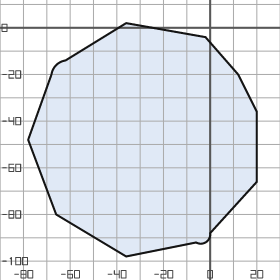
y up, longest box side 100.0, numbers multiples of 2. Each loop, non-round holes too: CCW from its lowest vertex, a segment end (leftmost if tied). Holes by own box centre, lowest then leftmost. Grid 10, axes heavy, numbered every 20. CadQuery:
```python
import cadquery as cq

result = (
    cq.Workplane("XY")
    .moveTo(-36.0, -98.0)
    .lineTo(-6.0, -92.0)
    .threePointArc((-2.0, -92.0), (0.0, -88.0))
    .lineTo(20.0, -66.0)
    .lineTo(20.0, -36.0)
    .lineTo(12.0, -20.0)
    .lineTo(-2.0, -4.0)
    .lineTo(-36.0, 2.0)
    .lineTo(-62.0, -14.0)
    .threePointArc((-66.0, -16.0), (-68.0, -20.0))
    .lineTo(-78.0, -48.0)
    .lineTo(-66.0, -80.0)
    .close()
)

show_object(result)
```